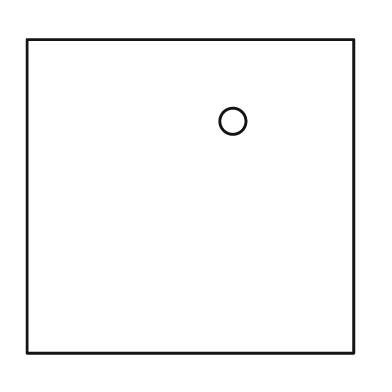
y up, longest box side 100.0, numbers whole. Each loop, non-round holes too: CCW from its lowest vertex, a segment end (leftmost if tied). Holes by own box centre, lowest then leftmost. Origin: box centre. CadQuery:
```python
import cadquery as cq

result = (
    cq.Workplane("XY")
    .moveTo(-50.0, -48.0)
    .lineTo(50.0, -48.0)
    .lineTo(50.0, 48.0)
    .lineTo(-50.0, 48.0)
    .close()
    .moveTo(13.0, 23.0)
    .circle(4.0)
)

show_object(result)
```